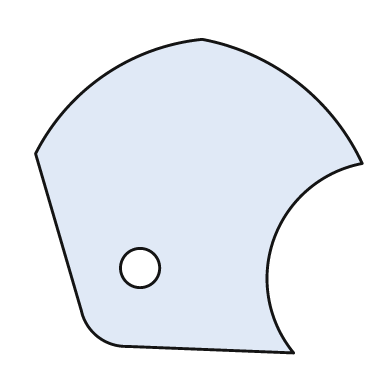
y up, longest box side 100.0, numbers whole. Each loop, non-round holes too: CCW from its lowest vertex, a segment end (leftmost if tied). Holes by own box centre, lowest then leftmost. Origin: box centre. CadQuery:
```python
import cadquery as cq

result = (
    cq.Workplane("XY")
    .moveTo(29.0, -48.0)
    .threePointArc((23.0, -13.0), (50.0, 10.0))
    .threePointArc((30.0, 35.0), (1.0, 48.0))
    .threePointArc((-29.0, 37.0), (-50.0, 13.0))
    .lineTo(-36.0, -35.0)
    .threePointArc((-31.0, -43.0), (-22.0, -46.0))
    .close()
    .moveTo(-18.0, -22.0)
    .circle(6.0)
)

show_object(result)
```